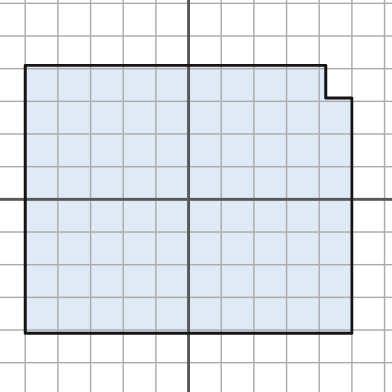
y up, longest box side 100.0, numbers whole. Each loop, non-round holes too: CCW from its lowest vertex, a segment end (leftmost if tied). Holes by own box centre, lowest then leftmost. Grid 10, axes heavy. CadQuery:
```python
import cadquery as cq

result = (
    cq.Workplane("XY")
    .moveTo(-50.0, -41.0)
    .lineTo(50.0, -41.0)
    .lineTo(50.0, 31.0)
    .lineTo(42.0, 31.0)
    .lineTo(42.0, 41.0)
    .lineTo(-50.0, 41.0)
    .close()
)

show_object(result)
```